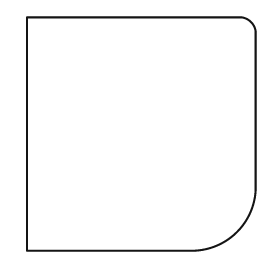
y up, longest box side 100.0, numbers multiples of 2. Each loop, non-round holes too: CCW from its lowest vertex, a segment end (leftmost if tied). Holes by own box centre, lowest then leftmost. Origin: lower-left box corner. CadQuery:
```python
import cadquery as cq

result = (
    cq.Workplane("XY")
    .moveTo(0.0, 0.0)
    .lineTo(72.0, 0.0)
    .threePointArc((90.0, 8.0), (98.0, 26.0))
    .lineTo(98.0, 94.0)
    .threePointArc((96.0, 98.0), (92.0, 100.0))
    .lineTo(0.0, 100.0)
    .close()
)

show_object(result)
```